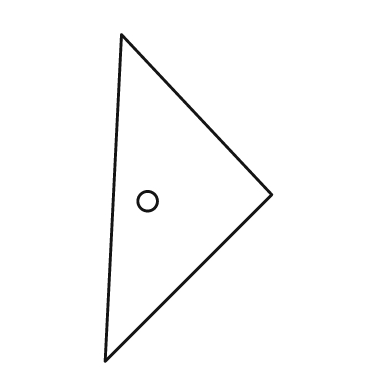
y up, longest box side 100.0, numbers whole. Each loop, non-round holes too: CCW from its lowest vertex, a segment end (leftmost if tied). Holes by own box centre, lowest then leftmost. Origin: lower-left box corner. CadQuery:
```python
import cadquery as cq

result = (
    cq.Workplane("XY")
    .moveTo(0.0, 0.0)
    .lineTo(51.0, 51.0)
    .lineTo(5.0, 100.0)
    .close()
    .moveTo(13.0, 49.0)
    .circle(3.0)
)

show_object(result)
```